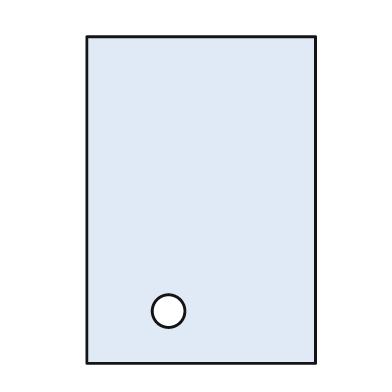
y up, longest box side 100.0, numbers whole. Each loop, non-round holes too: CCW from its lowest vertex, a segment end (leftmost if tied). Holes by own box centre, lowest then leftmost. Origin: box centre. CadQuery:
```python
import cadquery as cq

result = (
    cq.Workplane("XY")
    .moveTo(-35.0, -50.0)
    .lineTo(35.0, -50.0)
    .lineTo(35.0, 50.0)
    .lineTo(-35.0, 50.0)
    .close()
    .moveTo(-10.0, -34.0)
    .circle(5.0)
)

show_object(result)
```